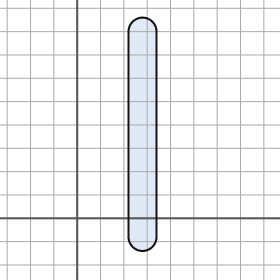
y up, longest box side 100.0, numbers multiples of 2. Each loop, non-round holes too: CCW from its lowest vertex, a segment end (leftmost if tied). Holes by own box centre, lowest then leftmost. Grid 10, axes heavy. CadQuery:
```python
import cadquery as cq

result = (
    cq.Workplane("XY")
    .moveTo(22.0, -8.0)
    .threePointArc((28.0, -14.0), (34.0, -8.0))
    .lineTo(34.0, 80.0)
    .threePointArc((28.0, 86.0), (22.0, 80.0))
    .close()
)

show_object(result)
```